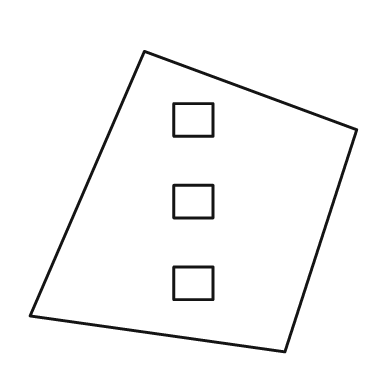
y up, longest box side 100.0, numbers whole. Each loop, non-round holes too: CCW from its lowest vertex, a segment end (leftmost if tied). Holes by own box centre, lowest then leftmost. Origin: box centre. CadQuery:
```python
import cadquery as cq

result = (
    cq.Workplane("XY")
    .moveTo(28.0, -46.0)
    .lineTo(50.0, 22.0)
    .lineTo(-15.0, 46.0)
    .lineTo(-50.0, -35.0)
    .close()
    .moveTo(-6.0, -30.0)
    .lineTo(6.0, -30.0)
    .lineTo(6.0, -20.0)
    .lineTo(-6.0, -20.0)
    .close()
    .moveTo(-6.0, -5.0)
    .lineTo(6.0, -5.0)
    .lineTo(6.0, 5.0)
    .lineTo(-6.0, 5.0)
    .close()
    .moveTo(-6.0, 20.0)
    .lineTo(6.0, 20.0)
    .lineTo(6.0, 30.0)
    .lineTo(-6.0, 30.0)
    .close()
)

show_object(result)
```